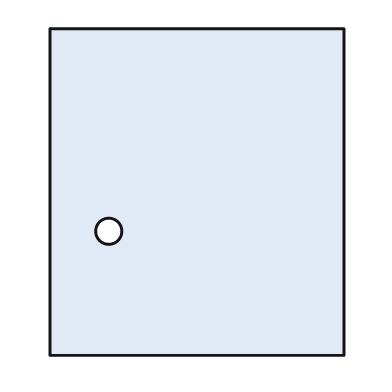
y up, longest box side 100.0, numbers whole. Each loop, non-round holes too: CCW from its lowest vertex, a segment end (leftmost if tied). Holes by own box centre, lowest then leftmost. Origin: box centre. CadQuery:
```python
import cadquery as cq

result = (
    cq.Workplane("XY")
    .moveTo(-45.0, -50.0)
    .lineTo(45.0, -50.0)
    .lineTo(45.0, 50.0)
    .lineTo(-45.0, 50.0)
    .close()
    .moveTo(-27.0, -12.0)
    .circle(4.0)
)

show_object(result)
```